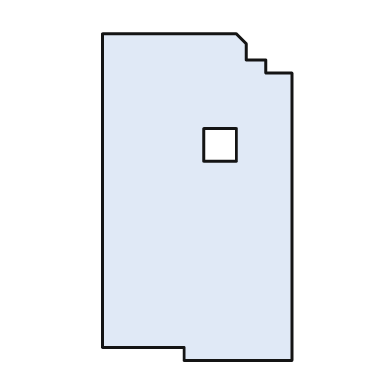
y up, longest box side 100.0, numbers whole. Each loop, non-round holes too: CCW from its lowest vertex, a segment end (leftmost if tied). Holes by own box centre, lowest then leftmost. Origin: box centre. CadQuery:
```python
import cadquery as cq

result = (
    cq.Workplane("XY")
    .moveTo(-4.0, -50.0)
    .lineTo(29.0, -50.0)
    .lineTo(29.0, 38.0)
    .lineTo(21.0, 38.0)
    .lineTo(21.0, 42.0)
    .lineTo(15.0, 42.0)
    .lineTo(15.0, 47.0)
    .lineTo(12.0, 50.0)
    .lineTo(-29.0, 50.0)
    .lineTo(-29.0, -46.0)
    .lineTo(-4.0, -46.0)
    .close()
    .moveTo(2.0, 11.0)
    .lineTo(12.0, 11.0)
    .lineTo(12.0, 21.0)
    .lineTo(2.0, 21.0)
    .close()
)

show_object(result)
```